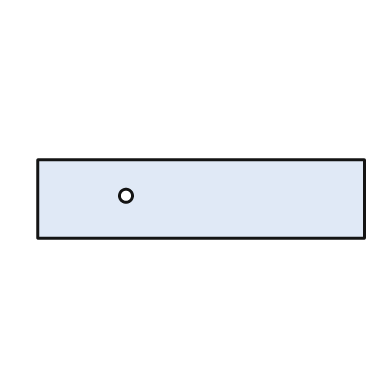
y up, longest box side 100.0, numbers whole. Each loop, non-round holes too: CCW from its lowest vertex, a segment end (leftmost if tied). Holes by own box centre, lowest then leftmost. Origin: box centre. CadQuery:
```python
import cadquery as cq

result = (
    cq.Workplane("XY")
    .moveTo(-50.0, -12.0)
    .lineTo(50.0, -12.0)
    .lineTo(50.0, 12.0)
    .lineTo(-50.0, 12.0)
    .close()
    .moveTo(-23.0, 1.0)
    .circle(2.0)
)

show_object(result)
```